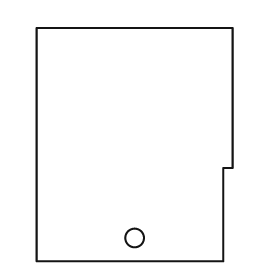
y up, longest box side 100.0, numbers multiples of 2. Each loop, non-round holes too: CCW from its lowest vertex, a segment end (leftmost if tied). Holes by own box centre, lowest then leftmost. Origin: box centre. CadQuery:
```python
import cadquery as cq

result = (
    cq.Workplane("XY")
    .moveTo(-42.0, -50.0)
    .lineTo(38.0, -50.0)
    .lineTo(38.0, -10.0)
    .lineTo(42.0, -10.0)
    .lineTo(42.0, 50.0)
    .lineTo(-42.0, 50.0)
    .close()
    .moveTo(0.0, -40.0)
    .circle(4.0)
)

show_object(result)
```